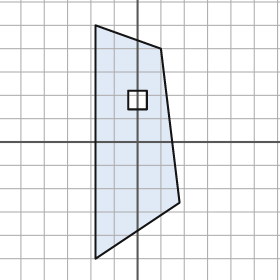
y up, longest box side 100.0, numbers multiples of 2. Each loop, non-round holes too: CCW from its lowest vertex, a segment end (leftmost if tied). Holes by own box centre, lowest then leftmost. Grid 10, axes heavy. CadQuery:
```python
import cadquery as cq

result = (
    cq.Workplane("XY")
    .moveTo(-18.0, -50.0)
    .lineTo(18.0, -26.0)
    .lineTo(10.0, 40.0)
    .lineTo(-18.0, 50.0)
    .close()
    .moveTo(-4.0, 14.0)
    .lineTo(4.0, 14.0)
    .lineTo(4.0, 22.0)
    .lineTo(-4.0, 22.0)
    .close()
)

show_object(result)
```